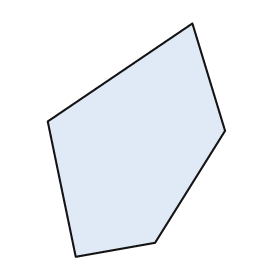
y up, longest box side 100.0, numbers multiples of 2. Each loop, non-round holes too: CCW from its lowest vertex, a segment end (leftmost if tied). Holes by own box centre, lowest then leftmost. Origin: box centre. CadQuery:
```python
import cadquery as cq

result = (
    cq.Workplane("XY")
    .moveTo(-26.0, -50.0)
    .lineTo(8.0, -44.0)
    .lineTo(38.0, 4.0)
    .lineTo(24.0, 50.0)
    .lineTo(-38.0, 8.0)
    .close()
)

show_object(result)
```